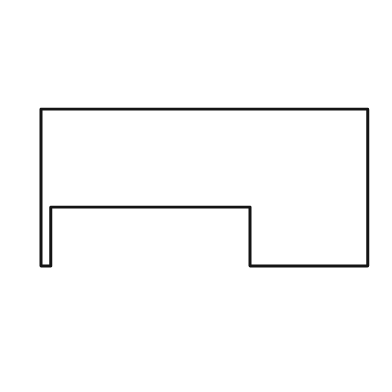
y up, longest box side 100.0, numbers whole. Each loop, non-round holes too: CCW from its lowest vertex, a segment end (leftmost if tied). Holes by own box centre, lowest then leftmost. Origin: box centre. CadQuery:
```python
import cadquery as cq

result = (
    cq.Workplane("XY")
    .moveTo(-50.0, -24.0)
    .lineTo(-47.0, -24.0)
    .lineTo(-47.0, -6.0)
    .lineTo(14.0, -6.0)
    .lineTo(14.0, -24.0)
    .lineTo(50.0, -24.0)
    .lineTo(50.0, 24.0)
    .lineTo(-50.0, 24.0)
    .close()
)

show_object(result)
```